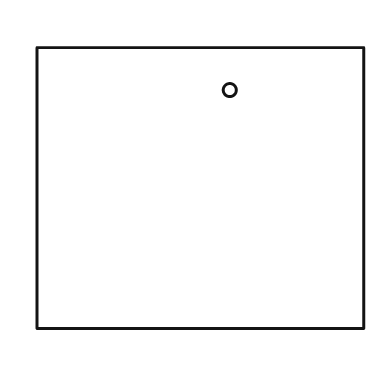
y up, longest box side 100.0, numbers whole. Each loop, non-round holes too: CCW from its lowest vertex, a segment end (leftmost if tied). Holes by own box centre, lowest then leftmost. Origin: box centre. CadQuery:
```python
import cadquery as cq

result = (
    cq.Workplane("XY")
    .moveTo(-50.0, -43.0)
    .lineTo(50.0, -43.0)
    .lineTo(50.0, 43.0)
    .lineTo(-50.0, 43.0)
    .close()
    .moveTo(9.0, 30.0)
    .circle(2.0)
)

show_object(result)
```